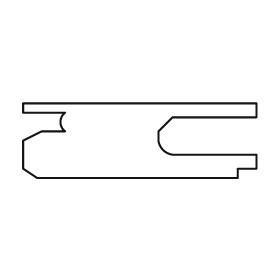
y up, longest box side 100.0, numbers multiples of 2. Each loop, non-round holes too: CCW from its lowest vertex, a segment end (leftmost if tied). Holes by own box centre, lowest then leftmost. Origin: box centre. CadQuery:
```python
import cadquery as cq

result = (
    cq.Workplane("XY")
    .moveTo(-44.0, -16.0)
    .lineTo(42.0, -16.0)
    .lineTo(42.0, -12.0)
    .lineTo(50.0, -12.0)
    .lineTo(50.0, -6.0)
    .lineTo(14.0, -6.0)
    .threePointArc((10.0, -4.0), (8.0, 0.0))
    .lineTo(8.0, 4.0)
    .lineTo(14.0, 10.0)
    .lineTo(50.0, 10.0)
    .lineTo(50.0, 16.0)
    .lineTo(-50.0, 16.0)
    .lineTo(-50.0, 12.0)
    .lineTo(-32.0, 12.0)
    .threePointArc((-34.0, 8.0), (-32.0, 4.0))
    .lineTo(-42.0, 4.0)
    .lineTo(-50.0, 0.0)
    .lineTo(-50.0, -12.0)
    .close()
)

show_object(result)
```